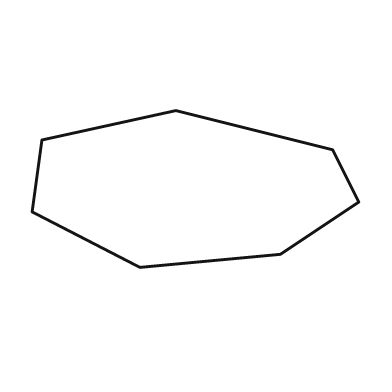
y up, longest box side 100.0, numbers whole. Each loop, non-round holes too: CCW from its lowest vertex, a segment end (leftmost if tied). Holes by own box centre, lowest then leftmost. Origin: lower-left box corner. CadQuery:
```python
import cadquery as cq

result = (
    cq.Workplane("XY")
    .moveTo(33.0, 0.0)
    .lineTo(76.0, 4.0)
    .lineTo(100.0, 20.0)
    .lineTo(92.0, 36.0)
    .lineTo(44.0, 48.0)
    .lineTo(3.0, 39.0)
    .lineTo(0.0, 17.0)
    .close()
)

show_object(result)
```